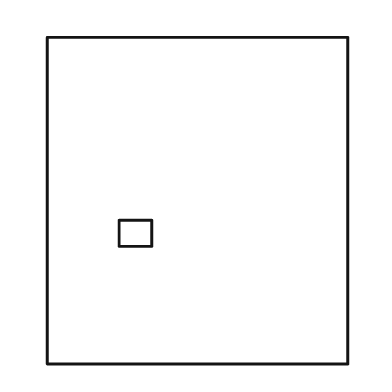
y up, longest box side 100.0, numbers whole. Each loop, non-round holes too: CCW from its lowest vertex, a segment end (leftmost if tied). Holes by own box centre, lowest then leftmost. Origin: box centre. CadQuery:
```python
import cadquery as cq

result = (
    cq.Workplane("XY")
    .moveTo(-46.0, -50.0)
    .lineTo(46.0, -50.0)
    .lineTo(46.0, 50.0)
    .lineTo(-46.0, 50.0)
    .close()
    .moveTo(-24.0, -14.0)
    .lineTo(-14.0, -14.0)
    .lineTo(-14.0, -6.0)
    .lineTo(-24.0, -6.0)
    .close()
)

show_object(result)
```